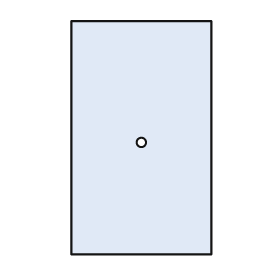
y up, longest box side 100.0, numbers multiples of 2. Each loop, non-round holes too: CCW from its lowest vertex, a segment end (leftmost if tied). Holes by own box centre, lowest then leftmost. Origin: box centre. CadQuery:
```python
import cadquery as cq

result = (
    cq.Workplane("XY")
    .moveTo(-30.0, -50.0)
    .lineTo(30.0, -50.0)
    .lineTo(30.0, 50.0)
    .lineTo(-30.0, 50.0)
    .close()
    .moveTo(0.0, -2.0)
    .circle(2.0)
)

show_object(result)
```